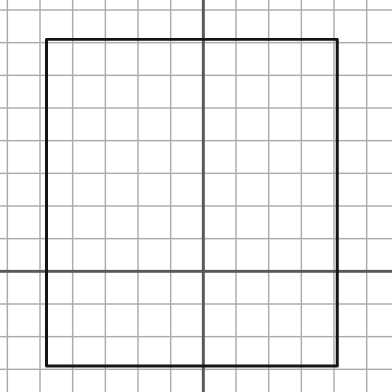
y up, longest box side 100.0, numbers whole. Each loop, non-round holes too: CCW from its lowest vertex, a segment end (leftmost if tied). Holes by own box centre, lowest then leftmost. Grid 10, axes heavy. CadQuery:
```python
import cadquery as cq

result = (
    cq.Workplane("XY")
    .moveTo(-48.0, -29.0)
    .lineTo(41.0, -29.0)
    .lineTo(41.0, 71.0)
    .lineTo(-48.0, 71.0)
    .close()
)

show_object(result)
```